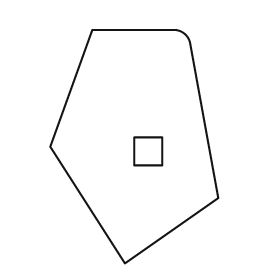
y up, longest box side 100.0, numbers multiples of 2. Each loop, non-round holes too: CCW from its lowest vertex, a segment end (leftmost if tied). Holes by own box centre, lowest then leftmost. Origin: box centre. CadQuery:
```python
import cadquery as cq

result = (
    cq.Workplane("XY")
    .moveTo(-4.0, -50.0)
    .lineTo(36.0, -22.0)
    .lineTo(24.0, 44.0)
    .threePointArc((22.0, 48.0), (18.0, 50.0))
    .lineTo(-18.0, 50.0)
    .lineTo(-36.0, 0.0)
    .close()
    .moveTo(0.0, -8.0)
    .lineTo(12.0, -8.0)
    .lineTo(12.0, 4.0)
    .lineTo(0.0, 4.0)
    .close()
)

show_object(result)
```